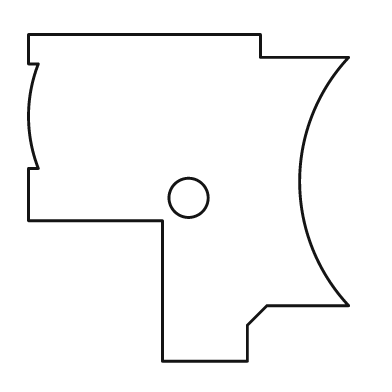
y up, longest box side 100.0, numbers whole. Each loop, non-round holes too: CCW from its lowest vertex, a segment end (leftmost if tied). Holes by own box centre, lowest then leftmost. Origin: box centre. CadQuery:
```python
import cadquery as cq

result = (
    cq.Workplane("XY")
    .moveTo(-8.0, -50.0)
    .lineTo(18.0, -50.0)
    .lineTo(18.0, -39.0)
    .lineTo(24.0, -33.0)
    .lineTo(49.0, -33.0)
    .threePointArc((34.0, 5.0), (49.0, 43.0))
    .lineTo(22.0, 43.0)
    .lineTo(22.0, 50.0)
    .lineTo(-49.0, 50.0)
    .lineTo(-49.0, 41.0)
    .lineTo(-46.0, 41.0)
    .threePointArc((-49.0, 25.0), (-46.0, 9.0))
    .lineTo(-49.0, 9.0)
    .lineTo(-49.0, -7.0)
    .lineTo(-8.0, -7.0)
    .close()
    .moveTo(0.0, 0.0)
    .circle(6.0)
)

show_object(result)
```